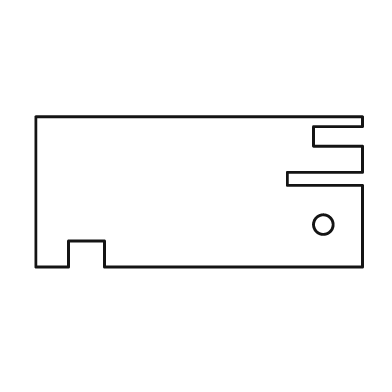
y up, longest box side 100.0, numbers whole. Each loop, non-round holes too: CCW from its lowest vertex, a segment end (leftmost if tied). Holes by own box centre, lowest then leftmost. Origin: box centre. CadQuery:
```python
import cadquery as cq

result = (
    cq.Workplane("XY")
    .moveTo(-50.0, -23.0)
    .lineTo(-40.0, -23.0)
    .lineTo(-40.0, -15.0)
    .lineTo(-29.0, -15.0)
    .lineTo(-29.0, -23.0)
    .lineTo(50.0, -23.0)
    .lineTo(50.0, 2.0)
    .lineTo(27.0, 2.0)
    .lineTo(27.0, 6.0)
    .lineTo(50.0, 6.0)
    .lineTo(50.0, 14.0)
    .lineTo(35.0, 14.0)
    .lineTo(35.0, 20.0)
    .lineTo(50.0, 20.0)
    .lineTo(50.0, 23.0)
    .lineTo(-50.0, 23.0)
    .close()
    .moveTo(38.0, -10.0)
    .circle(3.0)
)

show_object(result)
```